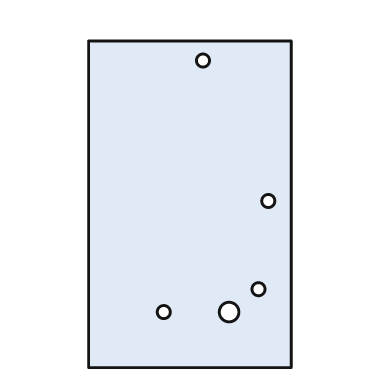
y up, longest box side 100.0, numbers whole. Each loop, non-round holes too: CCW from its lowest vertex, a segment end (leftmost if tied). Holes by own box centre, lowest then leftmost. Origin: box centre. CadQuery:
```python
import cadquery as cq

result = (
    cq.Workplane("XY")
    .moveTo(-31.0, -50.0)
    .lineTo(31.0, -50.0)
    .lineTo(31.0, 50.0)
    .lineTo(-31.0, 50.0)
    .close()
    .moveTo(-8.0, -33.0)
    .circle(2.0)
    .moveTo(12.0, -33.0)
    .circle(3.0)
    .moveTo(21.0, -26.0)
    .circle(2.0)
    .moveTo(24.0, 1.0)
    .circle(2.0)
    .moveTo(4.0, 44.0)
    .circle(2.0)
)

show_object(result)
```